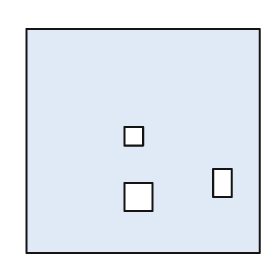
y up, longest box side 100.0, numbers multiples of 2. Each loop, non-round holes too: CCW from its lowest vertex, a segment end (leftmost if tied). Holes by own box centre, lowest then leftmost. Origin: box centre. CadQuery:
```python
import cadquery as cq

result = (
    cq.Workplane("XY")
    .moveTo(-50.0, -48.0)
    .lineTo(50.0, -48.0)
    .lineTo(50.0, 48.0)
    .lineTo(-50.0, 48.0)
    .close()
    .moveTo(-8.0, -30.0)
    .lineTo(4.0, -30.0)
    .lineTo(4.0, -18.0)
    .lineTo(-8.0, -18.0)
    .close()
    .moveTo(30.0, -24.0)
    .lineTo(38.0, -24.0)
    .lineTo(38.0, -12.0)
    .lineTo(30.0, -12.0)
    .close()
    .moveTo(-8.0, -2.0)
    .lineTo(0.0, -2.0)
    .lineTo(0.0, 6.0)
    .lineTo(-8.0, 6.0)
    .close()
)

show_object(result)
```